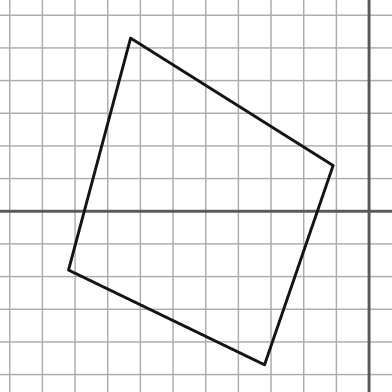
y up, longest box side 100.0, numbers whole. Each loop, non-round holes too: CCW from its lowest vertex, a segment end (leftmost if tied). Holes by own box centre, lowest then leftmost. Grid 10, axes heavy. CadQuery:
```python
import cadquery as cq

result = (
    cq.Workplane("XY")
    .moveTo(-32.0, -47.0)
    .lineTo(-11.0, 14.0)
    .lineTo(-73.0, 53.0)
    .lineTo(-92.0, -18.0)
    .close()
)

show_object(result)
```